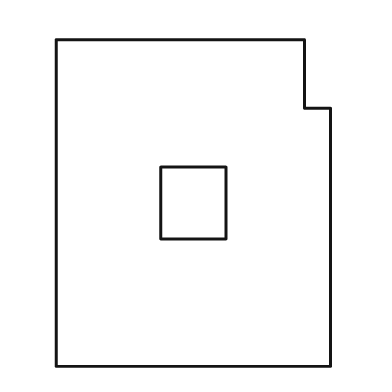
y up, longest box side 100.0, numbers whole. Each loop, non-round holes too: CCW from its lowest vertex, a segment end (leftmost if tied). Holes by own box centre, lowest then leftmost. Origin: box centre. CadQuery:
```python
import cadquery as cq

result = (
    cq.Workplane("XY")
    .moveTo(-42.0, -50.0)
    .lineTo(42.0, -50.0)
    .lineTo(42.0, 29.0)
    .lineTo(34.0, 29.0)
    .lineTo(34.0, 50.0)
    .lineTo(-42.0, 50.0)
    .close()
    .moveTo(-10.0, -11.0)
    .lineTo(10.0, -11.0)
    .lineTo(10.0, 11.0)
    .lineTo(-10.0, 11.0)
    .close()
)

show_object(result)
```